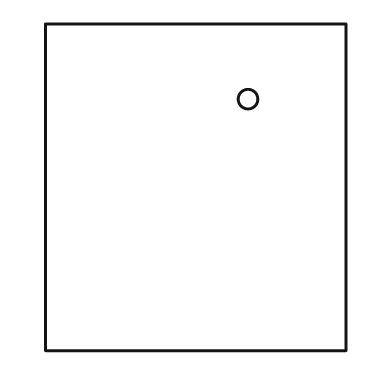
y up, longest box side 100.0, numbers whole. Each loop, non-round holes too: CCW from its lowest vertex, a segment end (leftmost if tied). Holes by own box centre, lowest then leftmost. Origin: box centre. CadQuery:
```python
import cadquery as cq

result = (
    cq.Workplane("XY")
    .moveTo(-46.0, -50.0)
    .lineTo(46.0, -50.0)
    .lineTo(46.0, 50.0)
    .lineTo(-46.0, 50.0)
    .close()
    .moveTo(16.0, 27.0)
    .circle(3.0)
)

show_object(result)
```